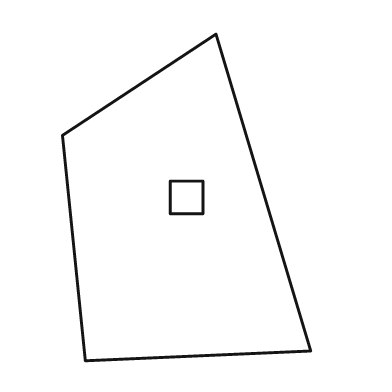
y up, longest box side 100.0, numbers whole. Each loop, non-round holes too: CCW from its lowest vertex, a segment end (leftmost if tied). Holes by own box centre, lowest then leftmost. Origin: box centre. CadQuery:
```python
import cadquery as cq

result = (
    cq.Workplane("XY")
    .moveTo(-31.0, -50.0)
    .lineTo(38.0, -47.0)
    .lineTo(9.0, 50.0)
    .lineTo(-38.0, 19.0)
    .close()
    .moveTo(-5.0, -5.0)
    .lineTo(5.0, -5.0)
    .lineTo(5.0, 5.0)
    .lineTo(-5.0, 5.0)
    .close()
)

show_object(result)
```